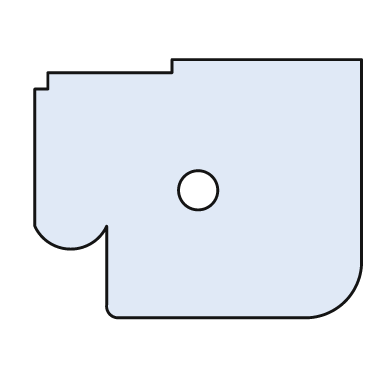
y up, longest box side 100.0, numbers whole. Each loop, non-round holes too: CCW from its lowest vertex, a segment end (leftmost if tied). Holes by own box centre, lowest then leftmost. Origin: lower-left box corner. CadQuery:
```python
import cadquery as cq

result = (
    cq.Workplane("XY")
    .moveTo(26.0, 0.0)
    .lineTo(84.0, 0.0)
    .threePointArc((95.0, 5.0), (100.0, 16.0))
    .lineTo(100.0, 79.0)
    .lineTo(42.0, 79.0)
    .lineTo(42.0, 75.0)
    .lineTo(4.0, 75.0)
    .lineTo(4.0, 70.0)
    .lineTo(0.0, 70.0)
    .lineTo(0.0, 28.0)
    .threePointArc((11.0, 21.0), (22.0, 28.0))
    .lineTo(22.0, 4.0)
    .threePointArc((23.0, 1.0), (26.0, 0.0))
    .close()
    .moveTo(50.0, 39.0)
    .circle(6.0)
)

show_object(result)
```